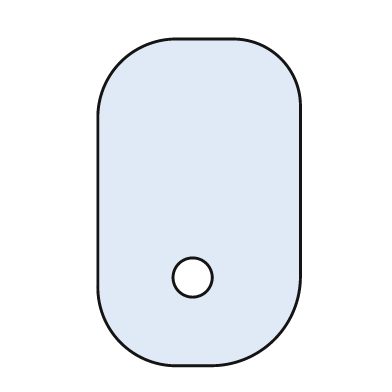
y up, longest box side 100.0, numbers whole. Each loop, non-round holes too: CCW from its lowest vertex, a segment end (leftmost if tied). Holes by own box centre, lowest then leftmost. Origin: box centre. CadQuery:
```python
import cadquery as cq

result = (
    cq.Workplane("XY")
    .moveTo(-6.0, -50.0)
    .lineTo(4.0, -50.0)
    .threePointArc((23.0, -42.0), (31.0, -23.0))
    .lineTo(31.0, 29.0)
    .threePointArc((25.0, 44.0), (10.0, 50.0))
    .lineTo(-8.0, 50.0)
    .threePointArc((-24.0, 43.0), (-31.0, 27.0))
    .lineTo(-31.0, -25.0)
    .threePointArc((-24.0, -43.0), (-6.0, -50.0))
    .close()
    .moveTo(-2.0, -23.0)
    .circle(6.0)
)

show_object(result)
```